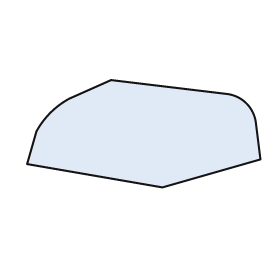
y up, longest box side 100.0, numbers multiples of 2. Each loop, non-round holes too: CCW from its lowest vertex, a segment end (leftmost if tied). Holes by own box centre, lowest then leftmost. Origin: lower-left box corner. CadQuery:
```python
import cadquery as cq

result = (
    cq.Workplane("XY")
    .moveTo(58.0, 0.0)
    .lineTo(100.0, 12.0)
    .lineTo(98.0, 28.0)
    .threePointArc((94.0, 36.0), (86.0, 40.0))
    .lineTo(36.0, 46.0)
    .lineTo(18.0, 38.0)
    .threePointArc((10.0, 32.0), (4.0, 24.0))
    .lineTo(0.0, 10.0)
    .close()
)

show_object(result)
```